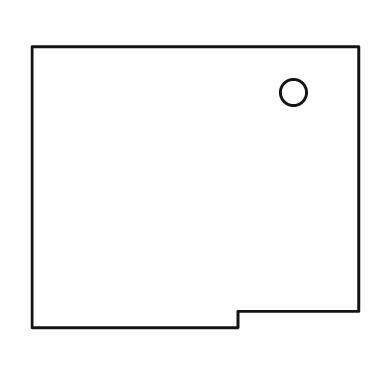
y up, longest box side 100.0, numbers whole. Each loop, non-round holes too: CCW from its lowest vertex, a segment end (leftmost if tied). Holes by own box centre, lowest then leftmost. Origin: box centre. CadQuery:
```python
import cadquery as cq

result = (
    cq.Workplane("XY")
    .moveTo(-50.0, -43.0)
    .lineTo(13.0, -43.0)
    .lineTo(13.0, -38.0)
    .lineTo(50.0, -38.0)
    .lineTo(50.0, 43.0)
    .lineTo(-50.0, 43.0)
    .close()
    .moveTo(30.0, 29.0)
    .circle(4.0)
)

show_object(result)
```